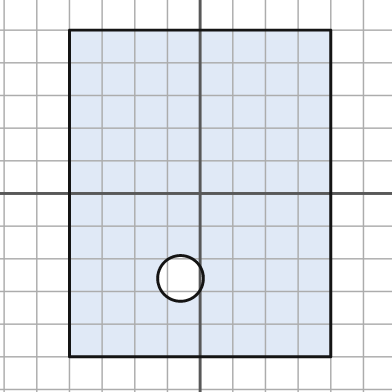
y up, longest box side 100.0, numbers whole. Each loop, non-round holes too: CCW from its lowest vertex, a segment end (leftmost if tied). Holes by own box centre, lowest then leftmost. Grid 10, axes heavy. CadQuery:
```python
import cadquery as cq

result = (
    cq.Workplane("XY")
    .moveTo(-40.0, -50.0)
    .lineTo(40.0, -50.0)
    .lineTo(40.0, 50.0)
    .lineTo(-40.0, 50.0)
    .close()
    .moveTo(-6.0, -26.0)
    .circle(7.0)
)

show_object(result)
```